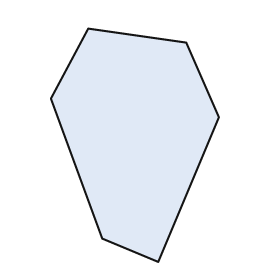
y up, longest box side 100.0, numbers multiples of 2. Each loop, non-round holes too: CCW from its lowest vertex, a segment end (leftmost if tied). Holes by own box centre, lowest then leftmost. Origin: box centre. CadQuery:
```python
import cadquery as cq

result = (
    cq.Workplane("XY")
    .moveTo(10.0, -50.0)
    .lineTo(36.0, 12.0)
    .lineTo(22.0, 44.0)
    .lineTo(-20.0, 50.0)
    .lineTo(-36.0, 20.0)
    .lineTo(-14.0, -40.0)
    .close()
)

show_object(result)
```